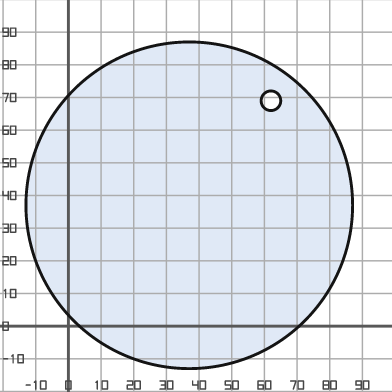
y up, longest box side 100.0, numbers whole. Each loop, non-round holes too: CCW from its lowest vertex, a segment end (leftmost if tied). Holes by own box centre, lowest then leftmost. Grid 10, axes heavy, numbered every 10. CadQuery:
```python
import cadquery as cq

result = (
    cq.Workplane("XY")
    .moveTo(37.0, 37.0)
    .circle(50.0)
    .moveTo(62.0, 69.0)
    .circle(3.0)
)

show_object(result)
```